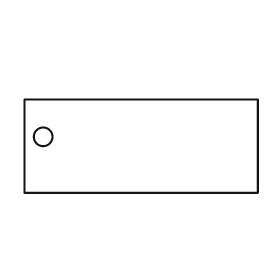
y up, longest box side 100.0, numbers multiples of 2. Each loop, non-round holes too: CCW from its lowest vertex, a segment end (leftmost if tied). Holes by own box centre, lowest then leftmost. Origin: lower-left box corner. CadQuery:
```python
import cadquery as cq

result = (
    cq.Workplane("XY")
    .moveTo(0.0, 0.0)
    .lineTo(100.0, 0.0)
    .lineTo(100.0, 40.0)
    .lineTo(0.0, 40.0)
    .close()
    .moveTo(8.0, 24.0)
    .circle(4.0)
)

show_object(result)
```